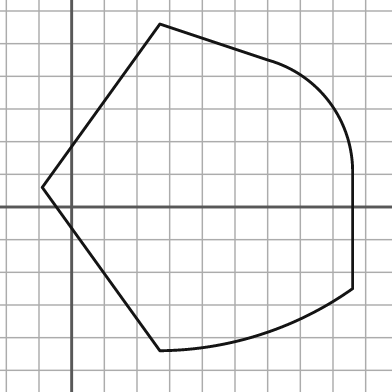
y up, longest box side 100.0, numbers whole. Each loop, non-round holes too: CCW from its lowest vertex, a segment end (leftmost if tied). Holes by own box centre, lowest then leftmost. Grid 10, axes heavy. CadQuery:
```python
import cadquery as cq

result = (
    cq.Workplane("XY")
    .moveTo(27.0, -44.0)
    .threePointArc((58.0, -39.0), (86.0, -25.0))
    .lineTo(86.0, 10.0)
    .threePointArc((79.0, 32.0), (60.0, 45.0))
    .lineTo(27.0, 56.0)
    .lineTo(-9.0, 6.0)
    .close()
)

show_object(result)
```